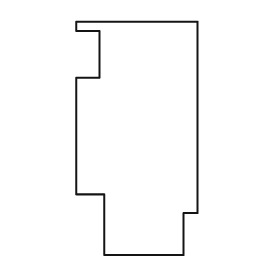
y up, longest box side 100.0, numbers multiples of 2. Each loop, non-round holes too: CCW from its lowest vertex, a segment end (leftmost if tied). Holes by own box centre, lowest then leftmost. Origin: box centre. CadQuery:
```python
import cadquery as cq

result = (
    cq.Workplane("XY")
    .moveTo(-14.0, -50.0)
    .lineTo(20.0, -50.0)
    .lineTo(20.0, -32.0)
    .lineTo(26.0, -32.0)
    .lineTo(26.0, 50.0)
    .lineTo(-26.0, 50.0)
    .lineTo(-26.0, 46.0)
    .lineTo(-16.0, 46.0)
    .lineTo(-16.0, 26.0)
    .lineTo(-26.0, 26.0)
    .lineTo(-26.0, -24.0)
    .lineTo(-14.0, -24.0)
    .close()
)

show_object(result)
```